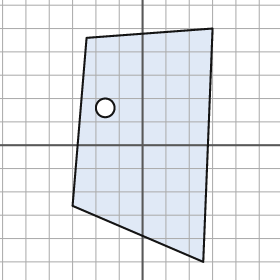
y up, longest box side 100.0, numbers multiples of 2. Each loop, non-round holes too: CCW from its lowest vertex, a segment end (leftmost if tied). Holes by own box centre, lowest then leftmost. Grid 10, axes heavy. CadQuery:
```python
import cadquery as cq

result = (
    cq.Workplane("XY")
    .moveTo(26.0, -50.0)
    .lineTo(30.0, 50.0)
    .lineTo(-24.0, 46.0)
    .lineTo(-30.0, -26.0)
    .close()
    .moveTo(-16.0, 16.0)
    .circle(4.0)
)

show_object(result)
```